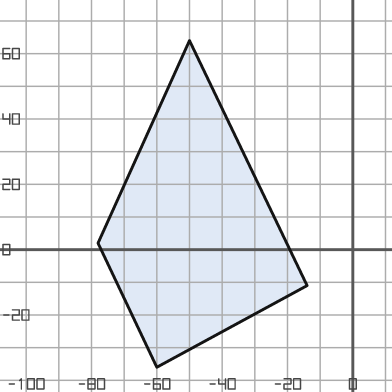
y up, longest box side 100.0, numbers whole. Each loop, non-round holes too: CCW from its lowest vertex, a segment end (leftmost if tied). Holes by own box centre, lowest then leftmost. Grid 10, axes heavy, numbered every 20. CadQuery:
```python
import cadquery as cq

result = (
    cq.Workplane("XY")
    .moveTo(-60.0, -36.0)
    .lineTo(-14.0, -11.0)
    .lineTo(-50.0, 64.0)
    .lineTo(-78.0, 2.0)
    .close()
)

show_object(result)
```